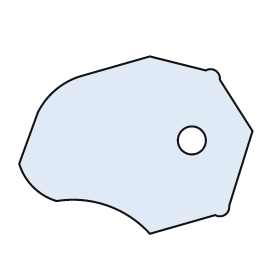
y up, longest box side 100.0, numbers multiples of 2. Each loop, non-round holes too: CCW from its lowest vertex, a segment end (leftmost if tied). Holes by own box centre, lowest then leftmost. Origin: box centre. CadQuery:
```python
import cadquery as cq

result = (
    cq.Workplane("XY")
    .moveTo(6.0, -38.0)
    .lineTo(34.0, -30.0)
    .threePointArc((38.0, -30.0), (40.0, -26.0))
    .lineTo(50.0, 6.0)
    .lineTo(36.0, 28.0)
    .threePointArc((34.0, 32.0), (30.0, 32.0))
    .lineTo(6.0, 38.0)
    .lineTo(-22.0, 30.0)
    .threePointArc((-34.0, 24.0), (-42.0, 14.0))
    .lineTo(-50.0, -8.0)
    .threePointArc((-44.0, -18.0), (-34.0, -24.0))
    .threePointArc((-12.0, -26.0), (6.0, -38.0))
    .close()
    .moveTo(24.0, 2.0)
    .circle(6.0)
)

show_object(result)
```